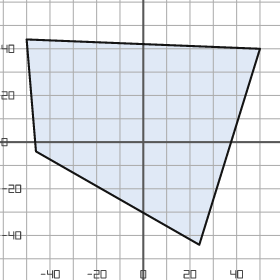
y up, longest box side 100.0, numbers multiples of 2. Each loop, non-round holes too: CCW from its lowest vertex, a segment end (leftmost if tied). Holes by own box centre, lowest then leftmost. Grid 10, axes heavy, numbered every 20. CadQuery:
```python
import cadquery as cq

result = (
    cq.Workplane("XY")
    .moveTo(24.0, -44.0)
    .lineTo(50.0, 40.0)
    .lineTo(-50.0, 44.0)
    .lineTo(-46.0, -4.0)
    .close()
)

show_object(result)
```